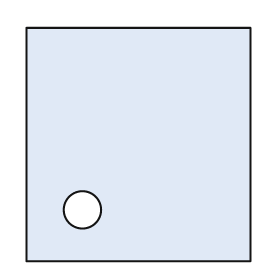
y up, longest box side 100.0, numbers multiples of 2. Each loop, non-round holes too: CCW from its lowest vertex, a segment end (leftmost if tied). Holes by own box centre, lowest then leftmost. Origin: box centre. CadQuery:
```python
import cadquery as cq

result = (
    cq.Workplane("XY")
    .moveTo(-48.0, -50.0)
    .lineTo(48.0, -50.0)
    .lineTo(48.0, 50.0)
    .lineTo(-48.0, 50.0)
    .close()
    .moveTo(-24.0, -28.0)
    .circle(8.0)
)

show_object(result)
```